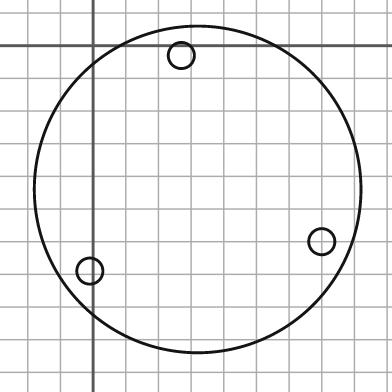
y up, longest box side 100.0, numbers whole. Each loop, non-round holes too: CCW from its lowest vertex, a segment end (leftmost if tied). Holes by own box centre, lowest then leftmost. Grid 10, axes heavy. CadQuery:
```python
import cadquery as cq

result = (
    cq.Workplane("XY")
    .moveTo(32.0, -44.0)
    .circle(50.0)
    .moveTo(-1.0, -69.0)
    .circle(4.0)
    .moveTo(70.0, -60.0)
    .circle(4.0)
    .moveTo(27.0, -3.0)
    .circle(4.0)
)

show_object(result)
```